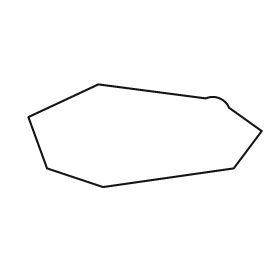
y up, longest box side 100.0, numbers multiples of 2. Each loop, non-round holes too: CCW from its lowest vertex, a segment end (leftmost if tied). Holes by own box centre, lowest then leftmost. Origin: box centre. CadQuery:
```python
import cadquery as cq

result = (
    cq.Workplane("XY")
    .moveTo(-18.0, -22.0)
    .lineTo(38.0, -14.0)
    .lineTo(50.0, 2.0)
    .lineTo(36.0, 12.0)
    .threePointArc((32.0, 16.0), (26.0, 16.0))
    .lineTo(-20.0, 22.0)
    .lineTo(-50.0, 8.0)
    .lineTo(-42.0, -14.0)
    .close()
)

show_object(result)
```